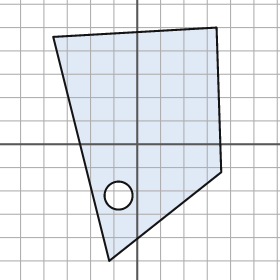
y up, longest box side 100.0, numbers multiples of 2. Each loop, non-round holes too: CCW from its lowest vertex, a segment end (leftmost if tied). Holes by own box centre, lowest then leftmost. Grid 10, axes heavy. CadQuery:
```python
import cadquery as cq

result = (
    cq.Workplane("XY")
    .moveTo(-12.0, -50.0)
    .lineTo(36.0, -12.0)
    .lineTo(34.0, 50.0)
    .lineTo(-36.0, 46.0)
    .close()
    .moveTo(-8.0, -22.0)
    .circle(6.0)
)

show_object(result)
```